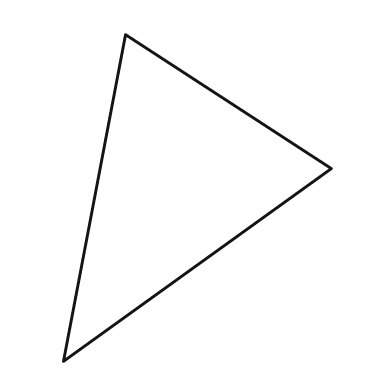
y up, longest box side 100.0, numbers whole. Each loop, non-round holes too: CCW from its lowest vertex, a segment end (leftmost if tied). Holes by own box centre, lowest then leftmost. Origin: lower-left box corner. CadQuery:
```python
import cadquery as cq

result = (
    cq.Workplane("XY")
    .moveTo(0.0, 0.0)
    .lineTo(82.0, 59.0)
    .lineTo(19.0, 100.0)
    .close()
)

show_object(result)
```